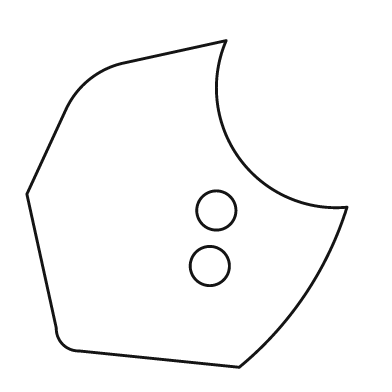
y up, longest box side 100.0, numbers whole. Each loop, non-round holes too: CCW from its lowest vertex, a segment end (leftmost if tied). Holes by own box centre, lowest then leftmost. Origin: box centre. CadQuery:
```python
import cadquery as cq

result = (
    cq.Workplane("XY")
    .moveTo(16.0, -50.0)
    .threePointArc((36.0, -28.0), (49.0, -1.0))
    .threePointArc((16.0, 14.0), (12.0, 50.0))
    .lineTo(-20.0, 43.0)
    .threePointArc((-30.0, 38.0), (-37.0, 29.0))
    .lineTo(-49.0, 3.0)
    .lineTo(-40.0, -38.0)
    .threePointArc((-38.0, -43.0), (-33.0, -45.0))
    .close()
    .moveTo(7.0, -19.0)
    .circle(6.0)
    .moveTo(9.0, -2.0)
    .circle(6.0)
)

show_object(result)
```